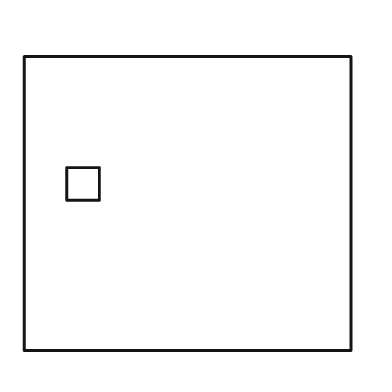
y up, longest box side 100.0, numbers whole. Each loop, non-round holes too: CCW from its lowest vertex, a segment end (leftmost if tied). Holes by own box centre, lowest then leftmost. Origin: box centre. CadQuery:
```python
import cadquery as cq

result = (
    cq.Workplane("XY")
    .moveTo(-50.0, -45.0)
    .lineTo(50.0, -45.0)
    .lineTo(50.0, 45.0)
    .lineTo(-50.0, 45.0)
    .close()
    .moveTo(-37.0, 1.0)
    .lineTo(-27.0, 1.0)
    .lineTo(-27.0, 11.0)
    .lineTo(-37.0, 11.0)
    .close()
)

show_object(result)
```